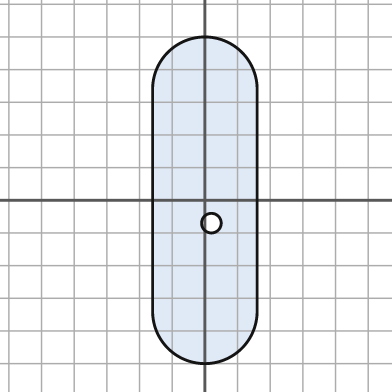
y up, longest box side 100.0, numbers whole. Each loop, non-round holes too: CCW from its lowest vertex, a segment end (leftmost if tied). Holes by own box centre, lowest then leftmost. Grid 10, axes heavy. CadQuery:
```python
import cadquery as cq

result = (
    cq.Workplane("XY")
    .moveTo(-16.0, -34.0)
    .threePointArc((0.0, -50.0), (16.0, -34.0))
    .lineTo(16.0, 34.0)
    .threePointArc((0.0, 50.0), (-16.0, 34.0))
    .close()
    .moveTo(2.0, -7.0)
    .circle(3.0)
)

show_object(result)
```